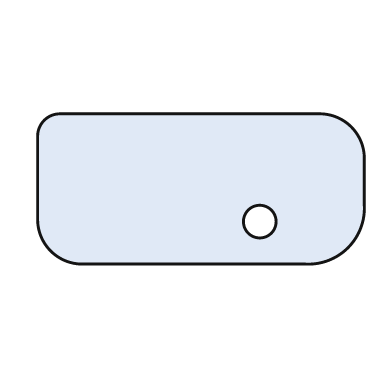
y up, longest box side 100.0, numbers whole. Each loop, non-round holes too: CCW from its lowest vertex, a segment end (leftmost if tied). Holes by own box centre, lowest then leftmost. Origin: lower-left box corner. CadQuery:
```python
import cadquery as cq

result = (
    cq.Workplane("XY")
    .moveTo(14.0, 0.0)
    .lineTo(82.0, 0.0)
    .threePointArc((95.0, 5.0), (100.0, 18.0))
    .lineTo(100.0, 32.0)
    .threePointArc((96.0, 42.0), (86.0, 46.0))
    .lineTo(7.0, 46.0)
    .threePointArc((2.0, 44.0), (0.0, 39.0))
    .lineTo(0.0, 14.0)
    .threePointArc((4.0, 4.0), (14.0, 0.0))
    .close()
    .moveTo(68.0, 13.0)
    .circle(5.0)
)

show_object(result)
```